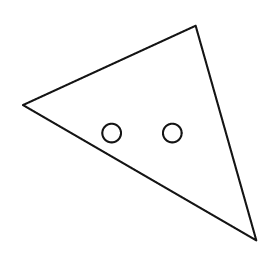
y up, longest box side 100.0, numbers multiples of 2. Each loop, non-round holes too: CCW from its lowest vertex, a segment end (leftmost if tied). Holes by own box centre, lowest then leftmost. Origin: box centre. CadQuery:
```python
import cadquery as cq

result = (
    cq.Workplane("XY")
    .moveTo(50.0, -46.0)
    .lineTo(24.0, 46.0)
    .lineTo(-50.0, 12.0)
    .close()
    .moveTo(-12.0, 0.0)
    .circle(4.0)
    .moveTo(14.0, 0.0)
    .circle(4.0)
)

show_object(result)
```